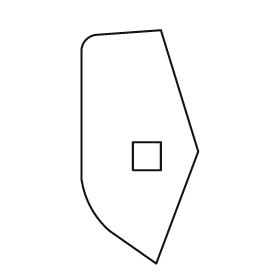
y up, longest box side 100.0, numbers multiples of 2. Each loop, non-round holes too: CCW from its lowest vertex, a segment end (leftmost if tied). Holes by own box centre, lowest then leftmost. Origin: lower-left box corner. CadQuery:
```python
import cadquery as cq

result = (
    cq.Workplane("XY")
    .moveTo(32.0, 0.0)
    .lineTo(50.0, 48.0)
    .lineTo(34.0, 100.0)
    .lineTo(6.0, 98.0)
    .threePointArc((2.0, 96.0), (0.0, 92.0))
    .lineTo(0.0, 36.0)
    .threePointArc((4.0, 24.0), (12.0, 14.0))
    .close()
    .moveTo(22.0, 40.0)
    .lineTo(34.0, 40.0)
    .lineTo(34.0, 52.0)
    .lineTo(22.0, 52.0)
    .close()
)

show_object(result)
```